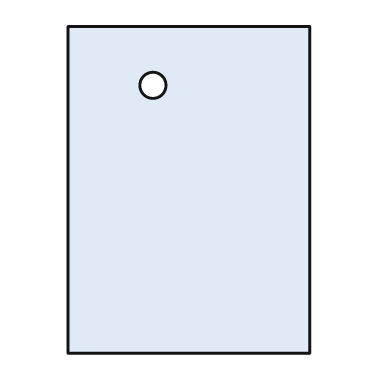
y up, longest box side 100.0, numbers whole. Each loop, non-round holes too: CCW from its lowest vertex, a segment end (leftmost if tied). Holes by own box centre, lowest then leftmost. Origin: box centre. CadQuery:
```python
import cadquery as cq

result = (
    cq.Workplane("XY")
    .moveTo(-37.0, -50.0)
    .lineTo(37.0, -50.0)
    .lineTo(37.0, 50.0)
    .lineTo(-37.0, 50.0)
    .close()
    .moveTo(-11.0, 32.0)
    .circle(4.0)
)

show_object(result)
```